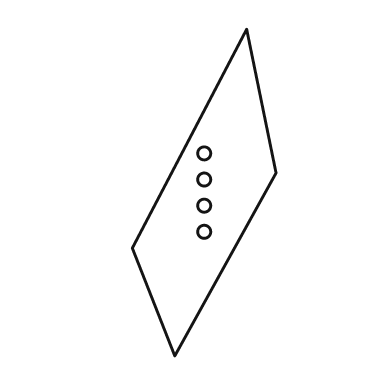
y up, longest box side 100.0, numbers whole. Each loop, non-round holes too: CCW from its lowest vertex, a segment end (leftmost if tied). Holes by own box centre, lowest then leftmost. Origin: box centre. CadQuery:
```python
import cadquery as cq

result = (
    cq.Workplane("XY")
    .moveTo(-9.0, -50.0)
    .lineTo(22.0, 6.0)
    .lineTo(13.0, 50.0)
    .lineTo(-22.0, -17.0)
    .close()
    .moveTo(0.0, -12.0)
    .circle(2.0)
    .moveTo(0.0, -4.0)
    .circle(2.0)
    .moveTo(0.0, 4.0)
    .circle(2.0)
    .moveTo(0.0, 12.0)
    .circle(2.0)
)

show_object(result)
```